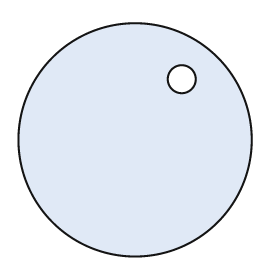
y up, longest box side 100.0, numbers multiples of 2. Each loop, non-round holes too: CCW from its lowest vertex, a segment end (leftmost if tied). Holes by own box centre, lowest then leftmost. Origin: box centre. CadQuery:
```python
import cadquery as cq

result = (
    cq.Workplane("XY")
    .moveTo(0.0, 0.0)
    .circle(50.0)
    .moveTo(20.0, 26.0)
    .circle(6.0)
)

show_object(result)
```